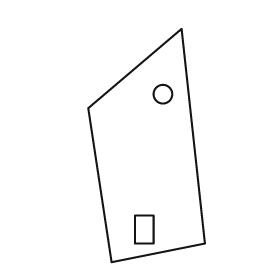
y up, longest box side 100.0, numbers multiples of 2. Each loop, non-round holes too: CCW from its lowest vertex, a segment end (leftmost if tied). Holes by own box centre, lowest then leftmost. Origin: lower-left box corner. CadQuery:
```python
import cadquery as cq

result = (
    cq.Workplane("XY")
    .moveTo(10.0, 0.0)
    .lineTo(50.0, 8.0)
    .lineTo(40.0, 100.0)
    .lineTo(0.0, 66.0)
    .close()
    .moveTo(20.0, 8.0)
    .lineTo(28.0, 8.0)
    .lineTo(28.0, 20.0)
    .lineTo(20.0, 20.0)
    .close()
    .moveTo(32.0, 72.0)
    .circle(4.0)
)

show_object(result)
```